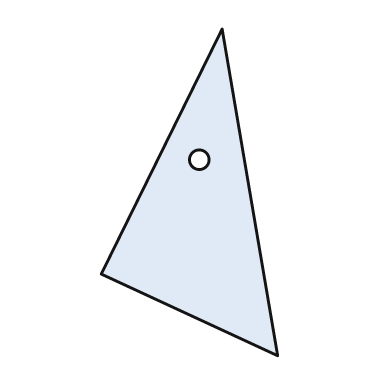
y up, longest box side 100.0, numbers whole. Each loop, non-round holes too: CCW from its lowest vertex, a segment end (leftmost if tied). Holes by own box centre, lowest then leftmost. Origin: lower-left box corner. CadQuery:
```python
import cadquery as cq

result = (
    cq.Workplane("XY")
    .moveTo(54.0, 0.0)
    .lineTo(37.0, 100.0)
    .lineTo(0.0, 25.0)
    .close()
    .moveTo(30.0, 60.0)
    .circle(3.0)
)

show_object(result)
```